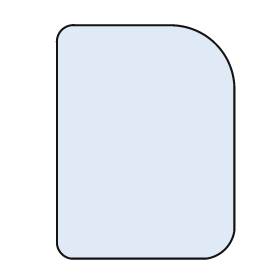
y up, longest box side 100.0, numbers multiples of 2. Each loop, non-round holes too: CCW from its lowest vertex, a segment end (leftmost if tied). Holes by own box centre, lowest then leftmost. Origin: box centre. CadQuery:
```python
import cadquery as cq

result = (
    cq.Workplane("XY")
    .moveTo(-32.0, -50.0)
    .lineTo(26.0, -50.0)
    .threePointArc((34.0, -46.0), (38.0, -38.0))
    .lineTo(38.0, 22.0)
    .threePointArc((30.0, 42.0), (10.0, 50.0))
    .lineTo(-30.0, 50.0)
    .threePointArc((-36.0, 48.0), (-38.0, 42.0))
    .lineTo(-38.0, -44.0)
    .threePointArc((-36.0, -48.0), (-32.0, -50.0))
    .close()
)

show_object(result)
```